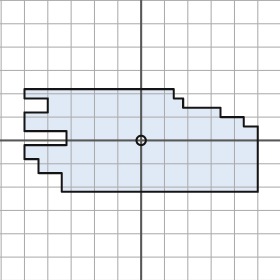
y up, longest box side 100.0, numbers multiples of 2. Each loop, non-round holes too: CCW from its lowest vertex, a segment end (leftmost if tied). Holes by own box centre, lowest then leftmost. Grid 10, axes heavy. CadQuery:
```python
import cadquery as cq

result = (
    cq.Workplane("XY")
    .moveTo(-34.0, -22.0)
    .lineTo(50.0, -22.0)
    .lineTo(50.0, 6.0)
    .lineTo(44.0, 6.0)
    .lineTo(44.0, 10.0)
    .lineTo(34.0, 10.0)
    .lineTo(34.0, 14.0)
    .lineTo(18.0, 14.0)
    .lineTo(18.0, 18.0)
    .lineTo(14.0, 18.0)
    .lineTo(14.0, 22.0)
    .lineTo(-50.0, 22.0)
    .lineTo(-50.0, 18.0)
    .lineTo(-40.0, 18.0)
    .lineTo(-40.0, 12.0)
    .lineTo(-50.0, 12.0)
    .lineTo(-50.0, 4.0)
    .lineTo(-32.0, 4.0)
    .lineTo(-32.0, -2.0)
    .lineTo(-50.0, -2.0)
    .lineTo(-50.0, -8.0)
    .lineTo(-44.0, -8.0)
    .lineTo(-44.0, -14.0)
    .lineTo(-34.0, -14.0)
    .close()
    .moveTo(0.0, 0.0)
    .circle(2.0)
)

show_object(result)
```